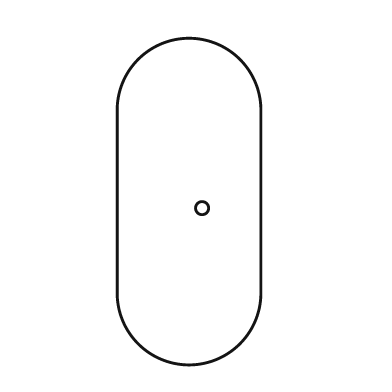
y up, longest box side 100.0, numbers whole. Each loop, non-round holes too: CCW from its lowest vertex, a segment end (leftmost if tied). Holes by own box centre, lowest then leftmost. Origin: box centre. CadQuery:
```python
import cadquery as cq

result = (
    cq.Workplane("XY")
    .moveTo(-22.0, -28.0)
    .threePointArc((0.0, -50.0), (22.0, -28.0))
    .lineTo(22.0, 28.0)
    .threePointArc((0.0, 50.0), (-22.0, 28.0))
    .close()
    .moveTo(4.0, -2.0)
    .circle(2.0)
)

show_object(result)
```